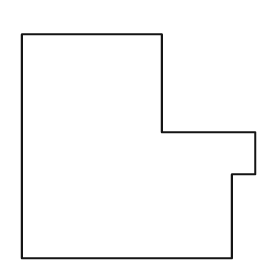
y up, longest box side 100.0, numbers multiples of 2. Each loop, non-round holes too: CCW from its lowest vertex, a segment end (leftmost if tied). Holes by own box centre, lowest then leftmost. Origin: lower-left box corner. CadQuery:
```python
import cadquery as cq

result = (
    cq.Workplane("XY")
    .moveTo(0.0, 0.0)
    .lineTo(90.0, 0.0)
    .lineTo(90.0, 36.0)
    .lineTo(100.0, 36.0)
    .lineTo(100.0, 54.0)
    .lineTo(60.0, 54.0)
    .lineTo(60.0, 96.0)
    .lineTo(0.0, 96.0)
    .close()
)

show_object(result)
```